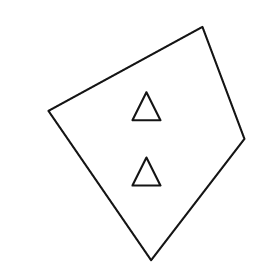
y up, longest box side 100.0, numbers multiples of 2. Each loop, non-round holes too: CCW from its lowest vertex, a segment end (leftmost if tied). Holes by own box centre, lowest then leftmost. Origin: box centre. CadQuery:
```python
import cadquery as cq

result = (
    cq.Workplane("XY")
    .moveTo(2.0, -50.0)
    .lineTo(42.0, 2.0)
    .lineTo(24.0, 50.0)
    .lineTo(-42.0, 14.0)
    .close()
    .moveTo(-6.0, -18.0)
    .lineTo(6.0, -18.0)
    .lineTo(0.0, -6.0)
    .close()
    .moveTo(-6.0, 10.0)
    .lineTo(6.0, 10.0)
    .lineTo(0.0, 22.0)
    .close()
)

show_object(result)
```